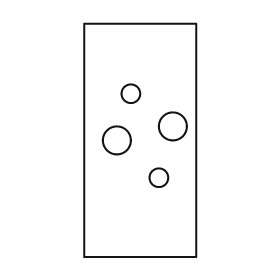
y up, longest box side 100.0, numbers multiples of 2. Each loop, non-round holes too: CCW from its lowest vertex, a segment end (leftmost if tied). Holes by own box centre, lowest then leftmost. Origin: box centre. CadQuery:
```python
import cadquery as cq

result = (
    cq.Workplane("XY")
    .moveTo(-24.0, -50.0)
    .lineTo(24.0, -50.0)
    .lineTo(24.0, 50.0)
    .lineTo(-24.0, 50.0)
    .close()
    .moveTo(8.0, -16.0)
    .circle(4.0)
    .moveTo(-10.0, 0.0)
    .circle(6.0)
    .moveTo(14.0, 6.0)
    .circle(6.0)
    .moveTo(-4.0, 20.0)
    .circle(4.0)
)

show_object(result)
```